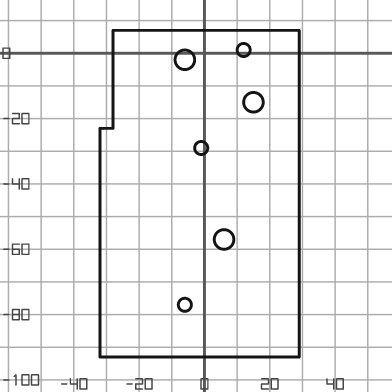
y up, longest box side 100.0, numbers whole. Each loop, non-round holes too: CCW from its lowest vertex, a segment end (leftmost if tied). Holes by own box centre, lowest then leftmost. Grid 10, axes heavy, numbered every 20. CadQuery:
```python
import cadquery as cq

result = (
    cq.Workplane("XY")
    .moveTo(-32.0, -93.0)
    .lineTo(29.0, -93.0)
    .lineTo(29.0, 7.0)
    .lineTo(-28.0, 7.0)
    .lineTo(-28.0, -23.0)
    .lineTo(-32.0, -23.0)
    .close()
    .moveTo(-6.0, -77.0)
    .circle(2.0)
    .moveTo(6.0, -57.0)
    .circle(3.0)
    .moveTo(-1.0, -29.0)
    .circle(2.0)
    .moveTo(15.0, -15.0)
    .circle(3.0)
    .moveTo(-6.0, -2.0)
    .circle(3.0)
    .moveTo(12.0, 1.0)
    .circle(2.0)
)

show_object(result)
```